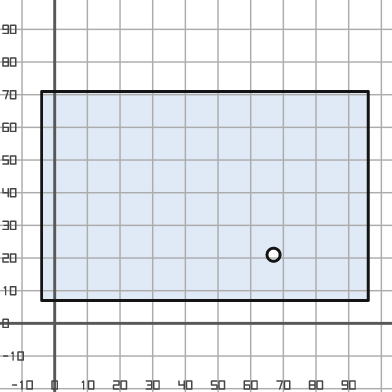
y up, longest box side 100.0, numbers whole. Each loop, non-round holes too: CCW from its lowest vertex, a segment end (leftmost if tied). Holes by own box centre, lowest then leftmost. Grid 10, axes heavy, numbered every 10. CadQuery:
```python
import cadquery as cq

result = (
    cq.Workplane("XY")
    .moveTo(-4.0, 7.0)
    .lineTo(96.0, 7.0)
    .lineTo(96.0, 71.0)
    .lineTo(-4.0, 71.0)
    .close()
    .moveTo(67.0, 21.0)
    .circle(2.0)
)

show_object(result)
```